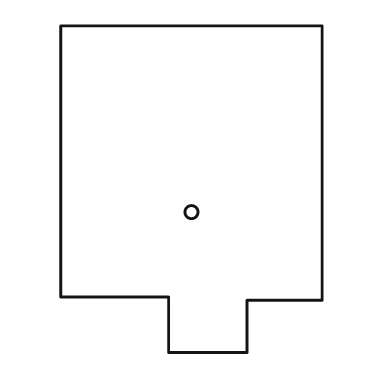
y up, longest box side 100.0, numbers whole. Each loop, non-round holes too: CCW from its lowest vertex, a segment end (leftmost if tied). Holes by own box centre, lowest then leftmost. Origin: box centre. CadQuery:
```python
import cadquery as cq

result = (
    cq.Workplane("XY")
    .moveTo(-7.0, -50.0)
    .lineTo(17.0, -50.0)
    .lineTo(17.0, -34.0)
    .lineTo(40.0, -34.0)
    .lineTo(40.0, 50.0)
    .lineTo(-40.0, 50.0)
    .lineTo(-40.0, -33.0)
    .lineTo(-7.0, -33.0)
    .close()
    .moveTo(0.0, -7.0)
    .circle(2.0)
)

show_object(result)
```